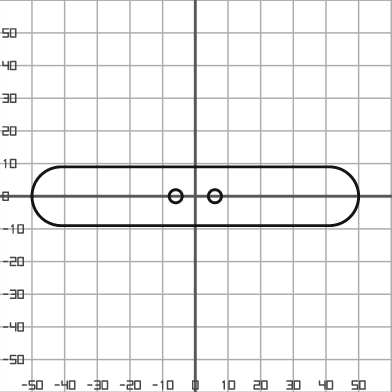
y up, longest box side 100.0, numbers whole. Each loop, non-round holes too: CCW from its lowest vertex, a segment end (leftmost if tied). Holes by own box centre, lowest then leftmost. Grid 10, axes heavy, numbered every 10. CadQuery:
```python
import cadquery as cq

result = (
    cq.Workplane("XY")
    .moveTo(-41.0, -9.0)
    .lineTo(41.0, -9.0)
    .threePointArc((50.0, 0.0), (41.0, 9.0))
    .lineTo(-41.0, 9.0)
    .threePointArc((-50.0, 0.0), (-41.0, -9.0))
    .close()
    .moveTo(-6.0, 0.0)
    .circle(2.0)
    .moveTo(6.0, 0.0)
    .circle(2.0)
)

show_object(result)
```